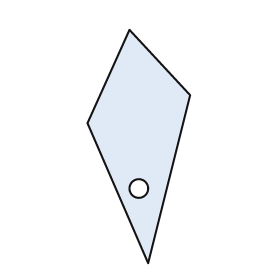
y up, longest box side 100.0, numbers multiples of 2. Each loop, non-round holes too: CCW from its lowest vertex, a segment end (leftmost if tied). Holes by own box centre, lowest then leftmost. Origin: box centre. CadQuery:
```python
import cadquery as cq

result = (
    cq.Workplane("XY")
    .moveTo(4.0, -50.0)
    .lineTo(22.0, 22.0)
    .lineTo(-4.0, 50.0)
    .lineTo(-22.0, 10.0)
    .close()
    .moveTo(0.0, -18.0)
    .circle(4.0)
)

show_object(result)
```